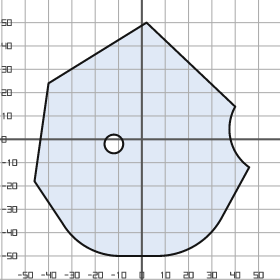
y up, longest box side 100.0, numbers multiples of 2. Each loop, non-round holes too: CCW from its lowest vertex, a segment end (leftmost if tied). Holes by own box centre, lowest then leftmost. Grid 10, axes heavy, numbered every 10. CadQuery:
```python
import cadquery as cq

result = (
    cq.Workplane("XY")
    .moveTo(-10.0, -50.0)
    .lineTo(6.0, -50.0)
    .threePointArc((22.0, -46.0), (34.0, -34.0))
    .lineTo(46.0, -12.0)
    .threePointArc((38.0, 0.0), (40.0, 14.0))
    .lineTo(2.0, 50.0)
    .lineTo(-40.0, 24.0)
    .lineTo(-46.0, -18.0)
    .lineTo(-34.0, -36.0)
    .threePointArc((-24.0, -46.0), (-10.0, -50.0))
    .close()
    .moveTo(-12.0, -2.0)
    .circle(4.0)
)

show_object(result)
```